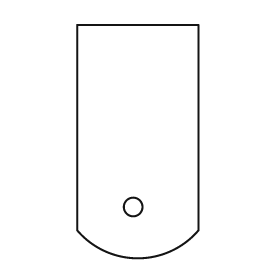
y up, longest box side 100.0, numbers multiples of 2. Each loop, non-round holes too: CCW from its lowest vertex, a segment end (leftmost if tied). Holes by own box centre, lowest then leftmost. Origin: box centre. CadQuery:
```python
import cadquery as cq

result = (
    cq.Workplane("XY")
    .moveTo(-26.0, -38.0)
    .threePointArc((0.0, -50.0), (26.0, -38.0))
    .lineTo(26.0, 50.0)
    .lineTo(-26.0, 50.0)
    .close()
    .moveTo(-2.0, -28.0)
    .circle(4.0)
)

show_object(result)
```